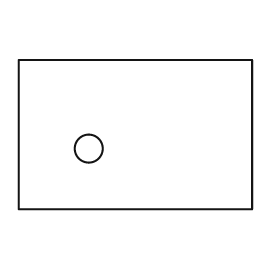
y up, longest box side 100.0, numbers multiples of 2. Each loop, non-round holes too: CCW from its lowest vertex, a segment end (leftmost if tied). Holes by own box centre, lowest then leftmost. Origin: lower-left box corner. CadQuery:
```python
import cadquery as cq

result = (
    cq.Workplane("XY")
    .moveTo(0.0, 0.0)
    .lineTo(100.0, 0.0)
    .lineTo(100.0, 64.0)
    .lineTo(0.0, 64.0)
    .close()
    .moveTo(30.0, 26.0)
    .circle(6.0)
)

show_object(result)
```